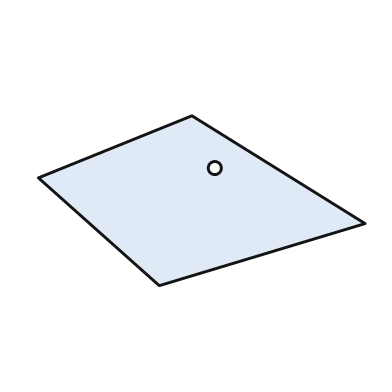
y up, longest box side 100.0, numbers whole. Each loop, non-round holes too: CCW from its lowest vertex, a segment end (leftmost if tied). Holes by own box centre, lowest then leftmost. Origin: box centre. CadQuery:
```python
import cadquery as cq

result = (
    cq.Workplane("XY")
    .moveTo(-13.0, -26.0)
    .lineTo(50.0, -7.0)
    .lineTo(-3.0, 26.0)
    .lineTo(-50.0, 7.0)
    .close()
    .moveTo(4.0, 10.0)
    .circle(2.0)
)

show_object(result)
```